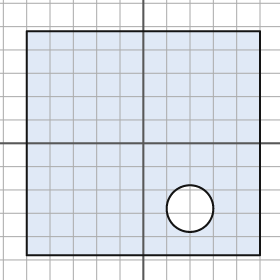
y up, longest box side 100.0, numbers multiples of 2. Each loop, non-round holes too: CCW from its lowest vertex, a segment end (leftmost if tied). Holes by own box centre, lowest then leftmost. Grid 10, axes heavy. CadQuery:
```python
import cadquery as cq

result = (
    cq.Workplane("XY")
    .moveTo(-50.0, -48.0)
    .lineTo(50.0, -48.0)
    .lineTo(50.0, 48.0)
    .lineTo(-50.0, 48.0)
    .close()
    .moveTo(20.0, -28.0)
    .circle(10.0)
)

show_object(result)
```